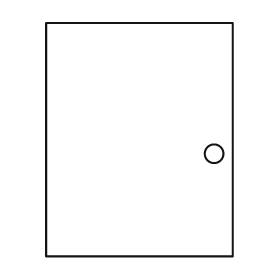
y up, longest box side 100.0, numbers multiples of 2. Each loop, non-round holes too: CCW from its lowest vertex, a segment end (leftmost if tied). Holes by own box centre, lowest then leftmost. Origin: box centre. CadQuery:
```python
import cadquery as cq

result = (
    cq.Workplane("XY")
    .moveTo(-40.0, -50.0)
    .lineTo(40.0, -50.0)
    .lineTo(40.0, 50.0)
    .lineTo(-40.0, 50.0)
    .close()
    .moveTo(32.0, -6.0)
    .circle(4.0)
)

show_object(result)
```